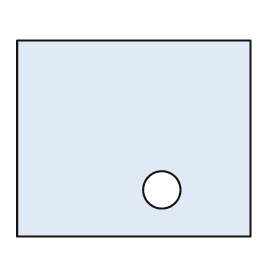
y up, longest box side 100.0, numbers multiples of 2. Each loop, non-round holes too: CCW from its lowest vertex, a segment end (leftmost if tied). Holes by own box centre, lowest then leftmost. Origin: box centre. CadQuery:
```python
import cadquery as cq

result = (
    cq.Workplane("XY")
    .moveTo(-50.0, -42.0)
    .lineTo(50.0, -42.0)
    .lineTo(50.0, 42.0)
    .lineTo(-50.0, 42.0)
    .close()
    .moveTo(12.0, -22.0)
    .circle(8.0)
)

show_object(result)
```